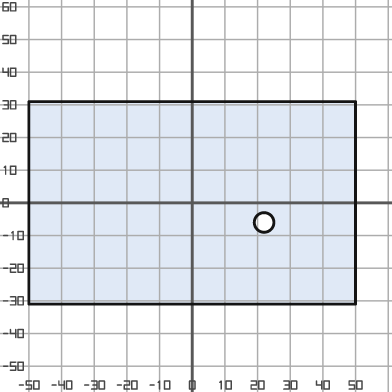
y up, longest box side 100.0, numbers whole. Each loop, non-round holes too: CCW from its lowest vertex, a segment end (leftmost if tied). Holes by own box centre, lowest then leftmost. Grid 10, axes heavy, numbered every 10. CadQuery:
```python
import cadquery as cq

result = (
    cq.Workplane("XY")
    .moveTo(-50.0, -31.0)
    .lineTo(50.0, -31.0)
    .lineTo(50.0, 31.0)
    .lineTo(-50.0, 31.0)
    .close()
    .moveTo(22.0, -6.0)
    .circle(3.0)
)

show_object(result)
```